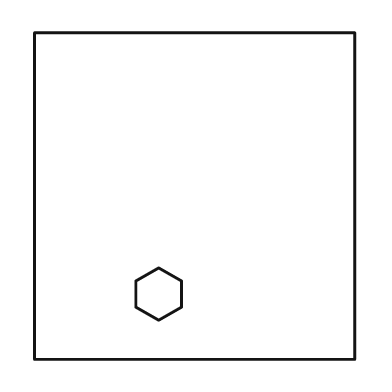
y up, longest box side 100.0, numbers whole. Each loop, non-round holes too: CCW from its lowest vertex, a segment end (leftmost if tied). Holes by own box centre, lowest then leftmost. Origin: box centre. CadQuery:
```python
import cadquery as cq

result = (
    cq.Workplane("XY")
    .moveTo(-49.0, -50.0)
    .lineTo(49.0, -50.0)
    .lineTo(49.0, 50.0)
    .lineTo(-49.0, 50.0)
    .close()
    .moveTo(-11.0, -38.0)
    .lineTo(-4.0, -34.0)
    .lineTo(-4.0, -26.0)
    .lineTo(-11.0, -22.0)
    .lineTo(-18.0, -26.0)
    .lineTo(-18.0, -34.0)
    .close()
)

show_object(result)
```